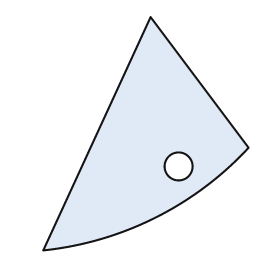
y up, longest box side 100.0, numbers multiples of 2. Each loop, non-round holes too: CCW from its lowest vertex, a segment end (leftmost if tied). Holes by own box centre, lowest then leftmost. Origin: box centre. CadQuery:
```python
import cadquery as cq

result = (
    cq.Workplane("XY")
    .moveTo(-44.0, -50.0)
    .threePointArc((4.0, -36.0), (44.0, -6.0))
    .lineTo(2.0, 50.0)
    .close()
    .moveTo(14.0, -14.0)
    .circle(6.0)
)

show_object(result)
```